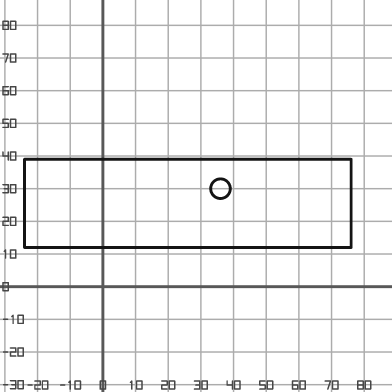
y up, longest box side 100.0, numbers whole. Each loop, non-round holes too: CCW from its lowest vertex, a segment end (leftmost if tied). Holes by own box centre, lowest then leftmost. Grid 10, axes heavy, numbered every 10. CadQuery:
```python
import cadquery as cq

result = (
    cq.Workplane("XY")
    .moveTo(-24.0, 12.0)
    .lineTo(76.0, 12.0)
    .lineTo(76.0, 39.0)
    .lineTo(-24.0, 39.0)
    .close()
    .moveTo(36.0, 30.0)
    .circle(3.0)
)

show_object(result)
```